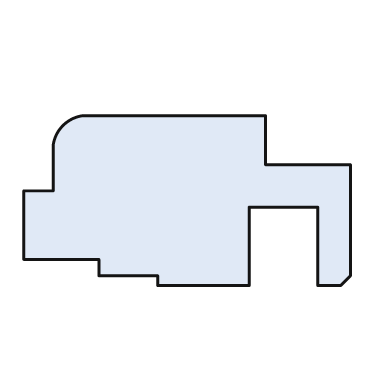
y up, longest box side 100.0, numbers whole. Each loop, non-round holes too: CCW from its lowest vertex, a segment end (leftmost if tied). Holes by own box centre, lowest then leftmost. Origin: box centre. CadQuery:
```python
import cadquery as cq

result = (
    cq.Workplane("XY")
    .moveTo(-9.0, -26.0)
    .lineTo(19.0, -26.0)
    .lineTo(19.0, -2.0)
    .lineTo(40.0, -2.0)
    .lineTo(40.0, -26.0)
    .lineTo(47.0, -26.0)
    .lineTo(50.0, -23.0)
    .lineTo(50.0, 11.0)
    .lineTo(24.0, 11.0)
    .lineTo(24.0, 26.0)
    .lineTo(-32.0, 26.0)
    .threePointArc((-38.0, 23.0), (-41.0, 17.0))
    .lineTo(-41.0, 3.0)
    .lineTo(-50.0, 3.0)
    .lineTo(-50.0, -18.0)
    .lineTo(-27.0, -18.0)
    .lineTo(-27.0, -23.0)
    .lineTo(-9.0, -23.0)
    .close()
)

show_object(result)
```